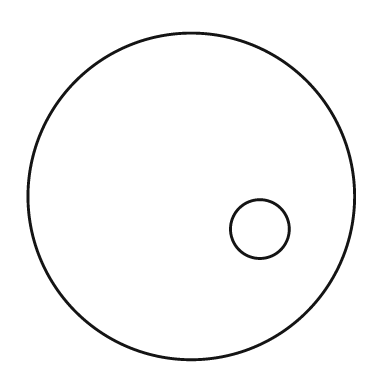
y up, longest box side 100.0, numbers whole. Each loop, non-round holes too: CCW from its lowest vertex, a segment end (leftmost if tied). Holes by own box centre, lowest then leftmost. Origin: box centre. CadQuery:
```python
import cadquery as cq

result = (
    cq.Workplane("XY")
    .moveTo(0.0, 0.0)
    .circle(50.0)
    .moveTo(21.0, -10.0)
    .circle(9.0)
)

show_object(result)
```